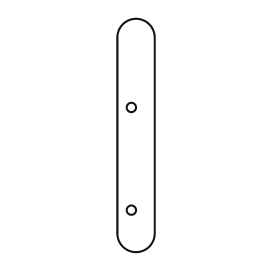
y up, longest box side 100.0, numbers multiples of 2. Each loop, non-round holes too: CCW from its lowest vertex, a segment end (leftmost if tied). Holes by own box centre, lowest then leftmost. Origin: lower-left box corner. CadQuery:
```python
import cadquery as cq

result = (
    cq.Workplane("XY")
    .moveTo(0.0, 8.0)
    .threePointArc((8.0, 0.0), (16.0, 8.0))
    .lineTo(16.0, 92.0)
    .threePointArc((8.0, 100.0), (0.0, 92.0))
    .close()
    .moveTo(6.0, 18.0)
    .circle(2.0)
    .moveTo(6.0, 62.0)
    .circle(2.0)
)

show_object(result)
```